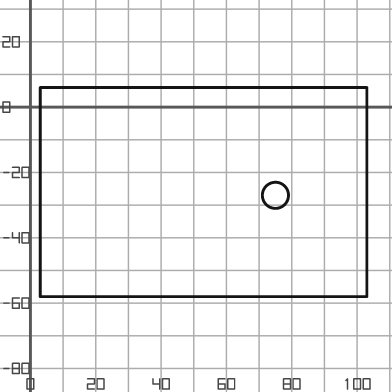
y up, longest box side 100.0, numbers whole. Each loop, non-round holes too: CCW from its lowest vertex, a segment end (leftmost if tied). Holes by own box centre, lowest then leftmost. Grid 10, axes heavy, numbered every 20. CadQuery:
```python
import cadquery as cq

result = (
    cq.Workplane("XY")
    .moveTo(3.0, -58.0)
    .lineTo(103.0, -58.0)
    .lineTo(103.0, 6.0)
    .lineTo(3.0, 6.0)
    .close()
    .moveTo(75.0, -27.0)
    .circle(4.0)
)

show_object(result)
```